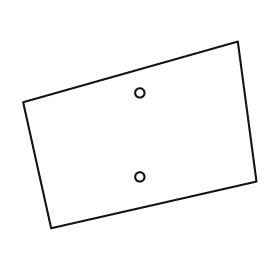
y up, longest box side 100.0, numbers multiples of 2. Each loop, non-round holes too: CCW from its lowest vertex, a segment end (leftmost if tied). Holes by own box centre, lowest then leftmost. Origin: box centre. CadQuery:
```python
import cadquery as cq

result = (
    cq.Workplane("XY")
    .moveTo(-38.0, -40.0)
    .lineTo(50.0, -20.0)
    .lineTo(42.0, 40.0)
    .lineTo(-50.0, 14.0)
    .close()
    .moveTo(0.0, -18.0)
    .circle(2.0)
    .moveTo(0.0, 18.0)
    .circle(2.0)
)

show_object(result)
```